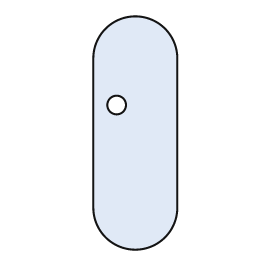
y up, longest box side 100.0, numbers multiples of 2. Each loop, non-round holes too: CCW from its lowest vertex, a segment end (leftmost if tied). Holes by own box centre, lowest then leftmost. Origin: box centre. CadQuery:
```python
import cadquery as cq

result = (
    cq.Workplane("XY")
    .moveTo(-18.0, -32.0)
    .threePointArc((0.0, -50.0), (18.0, -32.0))
    .lineTo(18.0, 32.0)
    .threePointArc((0.0, 50.0), (-18.0, 32.0))
    .close()
    .moveTo(-8.0, 12.0)
    .circle(4.0)
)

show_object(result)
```